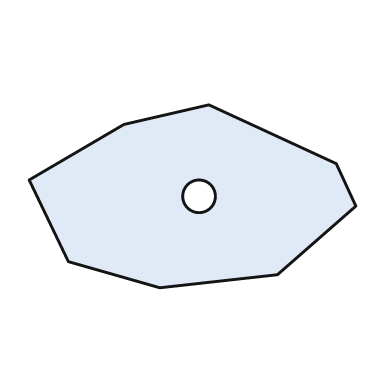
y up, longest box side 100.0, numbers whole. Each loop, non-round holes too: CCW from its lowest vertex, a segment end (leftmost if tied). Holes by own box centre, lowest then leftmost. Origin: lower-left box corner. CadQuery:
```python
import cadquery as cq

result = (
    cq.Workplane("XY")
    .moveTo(40.0, 0.0)
    .lineTo(76.0, 4.0)
    .lineTo(100.0, 25.0)
    .lineTo(94.0, 38.0)
    .lineTo(55.0, 56.0)
    .lineTo(29.0, 50.0)
    .lineTo(0.0, 33.0)
    .lineTo(12.0, 8.0)
    .close()
    .moveTo(52.0, 28.0)
    .circle(5.0)
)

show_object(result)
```